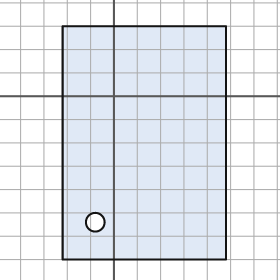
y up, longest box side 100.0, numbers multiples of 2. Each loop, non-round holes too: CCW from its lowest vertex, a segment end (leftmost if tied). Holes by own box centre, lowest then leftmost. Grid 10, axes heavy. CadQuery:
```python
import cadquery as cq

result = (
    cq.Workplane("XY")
    .moveTo(-22.0, -70.0)
    .lineTo(48.0, -70.0)
    .lineTo(48.0, 30.0)
    .lineTo(-22.0, 30.0)
    .close()
    .moveTo(-8.0, -54.0)
    .circle(4.0)
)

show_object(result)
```